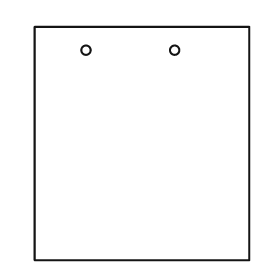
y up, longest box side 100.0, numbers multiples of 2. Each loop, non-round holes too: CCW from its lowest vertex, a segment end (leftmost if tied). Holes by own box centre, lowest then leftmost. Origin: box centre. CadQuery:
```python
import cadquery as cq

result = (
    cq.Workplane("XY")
    .moveTo(-46.0, -50.0)
    .lineTo(46.0, -50.0)
    .lineTo(46.0, 50.0)
    .lineTo(-46.0, 50.0)
    .close()
    .moveTo(-24.0, 40.0)
    .circle(2.0)
    .moveTo(14.0, 40.0)
    .circle(2.0)
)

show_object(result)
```